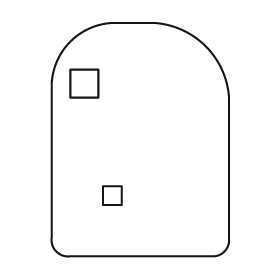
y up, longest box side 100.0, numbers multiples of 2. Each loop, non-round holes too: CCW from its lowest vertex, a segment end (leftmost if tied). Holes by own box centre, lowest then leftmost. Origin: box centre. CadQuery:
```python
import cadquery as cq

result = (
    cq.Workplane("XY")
    .moveTo(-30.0, -50.0)
    .lineTo(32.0, -50.0)
    .threePointArc((36.0, -48.0), (38.0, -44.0))
    .lineTo(38.0, 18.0)
    .threePointArc((28.0, 40.0), (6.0, 50.0))
    .lineTo(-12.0, 50.0)
    .threePointArc((-30.0, 42.0), (-38.0, 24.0))
    .lineTo(-38.0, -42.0)
    .threePointArc((-36.0, -48.0), (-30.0, -50.0))
    .close()
    .moveTo(-16.0, -28.0)
    .lineTo(-8.0, -28.0)
    .lineTo(-8.0, -20.0)
    .lineTo(-16.0, -20.0)
    .close()
    .moveTo(-30.0, 18.0)
    .lineTo(-18.0, 18.0)
    .lineTo(-18.0, 30.0)
    .lineTo(-30.0, 30.0)
    .close()
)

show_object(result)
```